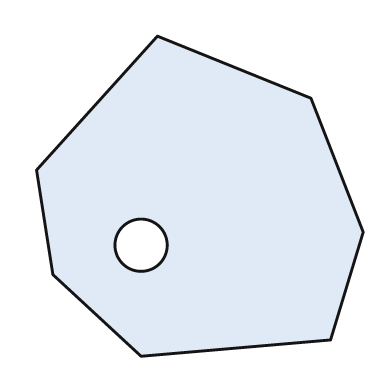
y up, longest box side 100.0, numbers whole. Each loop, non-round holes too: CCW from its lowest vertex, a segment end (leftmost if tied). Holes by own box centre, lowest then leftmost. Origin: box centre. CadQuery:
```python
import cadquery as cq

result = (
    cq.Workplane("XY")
    .moveTo(-18.0, -49.0)
    .lineTo(40.0, -44.0)
    .lineTo(50.0, -11.0)
    .lineTo(34.0, 30.0)
    .lineTo(-13.0, 49.0)
    .lineTo(-50.0, 8.0)
    .lineTo(-45.0, -24.0)
    .close()
    .moveTo(-18.0, -15.0)
    .circle(8.0)
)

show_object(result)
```